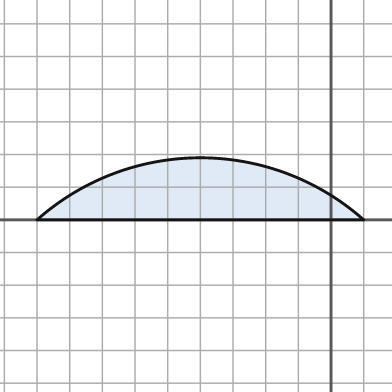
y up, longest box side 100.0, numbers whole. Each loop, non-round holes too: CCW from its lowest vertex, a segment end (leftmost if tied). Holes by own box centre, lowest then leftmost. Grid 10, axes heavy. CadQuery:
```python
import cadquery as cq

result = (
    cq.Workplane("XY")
    .moveTo(-90.0, 0.0)
    .lineTo(10.0, 0.0)
    .threePointArc((-40.0, 19.0), (-90.0, 0.0))
    .close()
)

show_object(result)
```